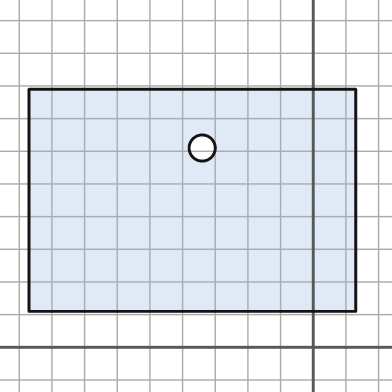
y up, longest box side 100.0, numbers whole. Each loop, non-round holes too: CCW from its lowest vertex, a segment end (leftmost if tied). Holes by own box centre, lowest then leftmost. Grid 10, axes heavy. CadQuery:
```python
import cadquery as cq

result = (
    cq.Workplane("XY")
    .moveTo(-87.0, 11.0)
    .lineTo(13.0, 11.0)
    .lineTo(13.0, 79.0)
    .lineTo(-87.0, 79.0)
    .close()
    .moveTo(-34.0, 61.0)
    .circle(4.0)
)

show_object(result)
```